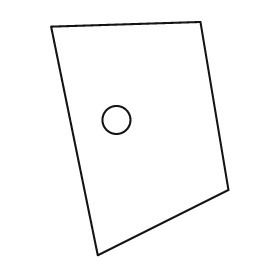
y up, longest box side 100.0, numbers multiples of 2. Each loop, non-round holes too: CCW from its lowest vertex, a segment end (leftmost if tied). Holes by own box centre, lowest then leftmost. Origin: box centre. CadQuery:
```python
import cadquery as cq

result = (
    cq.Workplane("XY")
    .moveTo(-18.0, -50.0)
    .lineTo(38.0, -22.0)
    .lineTo(26.0, 50.0)
    .lineTo(-38.0, 48.0)
    .close()
    .moveTo(-10.0, 8.0)
    .circle(6.0)
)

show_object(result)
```